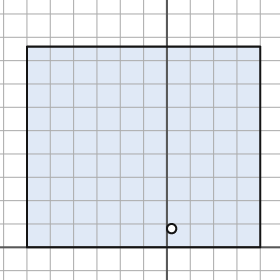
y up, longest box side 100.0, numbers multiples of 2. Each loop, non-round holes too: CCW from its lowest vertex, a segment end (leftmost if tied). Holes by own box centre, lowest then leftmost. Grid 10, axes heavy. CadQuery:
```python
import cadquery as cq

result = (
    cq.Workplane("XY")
    .moveTo(-60.0, 0.0)
    .lineTo(40.0, 0.0)
    .lineTo(40.0, 86.0)
    .lineTo(-60.0, 86.0)
    .close()
    .moveTo(2.0, 8.0)
    .circle(2.0)
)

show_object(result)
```